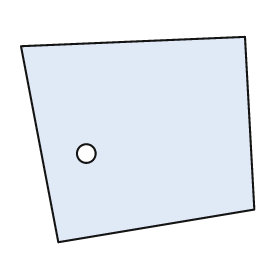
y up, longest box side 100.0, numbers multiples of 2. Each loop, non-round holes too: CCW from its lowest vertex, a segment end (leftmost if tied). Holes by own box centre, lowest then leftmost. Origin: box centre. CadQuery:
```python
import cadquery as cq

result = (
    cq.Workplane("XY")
    .moveTo(-34.0, -44.0)
    .lineTo(50.0, -30.0)
    .lineTo(46.0, 44.0)
    .lineTo(-50.0, 40.0)
    .close()
    .moveTo(-22.0, -6.0)
    .circle(4.0)
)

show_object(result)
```